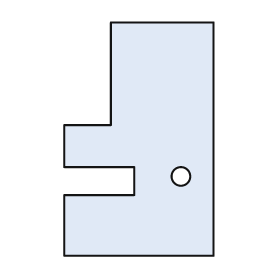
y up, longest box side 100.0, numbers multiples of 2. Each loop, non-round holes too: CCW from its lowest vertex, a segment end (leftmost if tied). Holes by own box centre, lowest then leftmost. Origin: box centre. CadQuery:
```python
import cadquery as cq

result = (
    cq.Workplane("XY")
    .moveTo(-32.0, -50.0)
    .lineTo(32.0, -50.0)
    .lineTo(32.0, 50.0)
    .lineTo(-12.0, 50.0)
    .lineTo(-12.0, 6.0)
    .lineTo(-32.0, 6.0)
    .lineTo(-32.0, -12.0)
    .lineTo(-2.0, -12.0)
    .lineTo(-2.0, -24.0)
    .lineTo(-32.0, -24.0)
    .close()
    .moveTo(18.0, -16.0)
    .circle(4.0)
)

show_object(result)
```